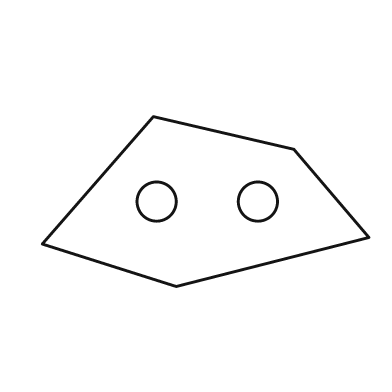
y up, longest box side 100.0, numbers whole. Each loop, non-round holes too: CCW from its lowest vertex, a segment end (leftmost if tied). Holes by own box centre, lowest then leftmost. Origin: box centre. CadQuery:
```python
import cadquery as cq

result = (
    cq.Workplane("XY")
    .moveTo(-9.0, -26.0)
    .lineTo(50.0, -11.0)
    .lineTo(27.0, 16.0)
    .lineTo(-16.0, 26.0)
    .lineTo(-50.0, -13.0)
    .close()
    .moveTo(-15.0, 0.0)
    .circle(6.0)
    .moveTo(16.0, 0.0)
    .circle(6.0)
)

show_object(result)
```